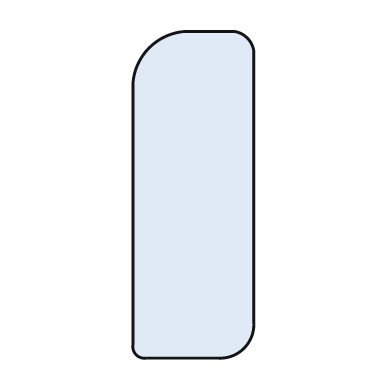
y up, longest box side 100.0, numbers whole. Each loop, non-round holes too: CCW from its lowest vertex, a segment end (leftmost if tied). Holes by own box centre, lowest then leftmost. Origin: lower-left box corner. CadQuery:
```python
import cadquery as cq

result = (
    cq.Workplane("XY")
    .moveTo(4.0, 0.0)
    .lineTo(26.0, 0.0)
    .threePointArc((34.0, 3.0), (37.0, 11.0))
    .lineTo(37.0, 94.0)
    .threePointArc((35.0, 98.0), (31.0, 100.0))
    .lineTo(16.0, 100.0)
    .threePointArc((5.0, 95.0), (0.0, 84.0))
    .lineTo(0.0, 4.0)
    .threePointArc((1.0, 1.0), (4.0, 0.0))
    .close()
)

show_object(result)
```